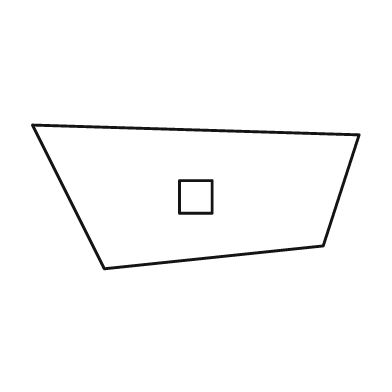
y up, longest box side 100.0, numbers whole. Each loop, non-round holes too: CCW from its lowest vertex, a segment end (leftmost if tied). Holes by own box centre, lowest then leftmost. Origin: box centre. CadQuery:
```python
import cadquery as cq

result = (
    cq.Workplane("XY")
    .moveTo(-28.0, -22.0)
    .lineTo(39.0, -15.0)
    .lineTo(50.0, 19.0)
    .lineTo(-50.0, 22.0)
    .close()
    .moveTo(-5.0, -5.0)
    .lineTo(5.0, -5.0)
    .lineTo(5.0, 5.0)
    .lineTo(-5.0, 5.0)
    .close()
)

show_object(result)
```